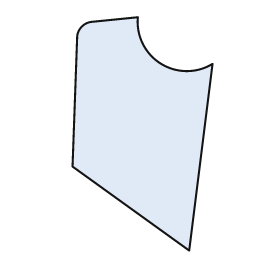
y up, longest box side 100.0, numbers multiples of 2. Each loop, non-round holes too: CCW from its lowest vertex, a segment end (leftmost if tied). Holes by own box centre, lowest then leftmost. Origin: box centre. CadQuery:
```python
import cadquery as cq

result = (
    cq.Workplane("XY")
    .moveTo(20.0, -50.0)
    .lineTo(30.0, 30.0)
    .threePointArc((8.0, 30.0), (-2.0, 50.0))
    .lineTo(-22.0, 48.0)
    .threePointArc((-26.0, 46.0), (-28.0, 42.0))
    .lineTo(-30.0, -14.0)
    .close()
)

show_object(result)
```